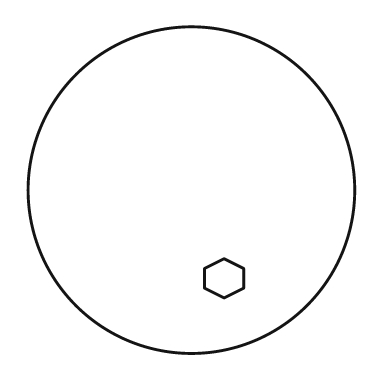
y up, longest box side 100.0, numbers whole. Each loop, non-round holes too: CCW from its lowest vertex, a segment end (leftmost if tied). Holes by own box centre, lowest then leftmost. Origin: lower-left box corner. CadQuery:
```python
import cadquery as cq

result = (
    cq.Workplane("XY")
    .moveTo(50.0, 50.0)
    .circle(50.0)
    .moveTo(60.0, 17.0)
    .lineTo(66.0, 20.0)
    .lineTo(66.0, 26.0)
    .lineTo(60.0, 29.0)
    .lineTo(54.0, 26.0)
    .lineTo(54.0, 20.0)
    .close()
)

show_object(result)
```